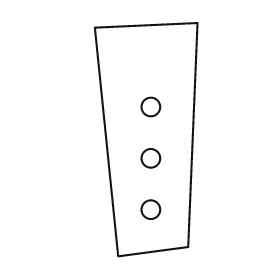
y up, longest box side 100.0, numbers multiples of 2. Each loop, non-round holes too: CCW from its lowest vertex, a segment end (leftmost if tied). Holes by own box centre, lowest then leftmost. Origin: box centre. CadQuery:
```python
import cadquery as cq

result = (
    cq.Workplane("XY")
    .moveTo(-12.0, -50.0)
    .lineTo(18.0, -46.0)
    .lineTo(22.0, 50.0)
    .lineTo(-22.0, 48.0)
    .close()
    .moveTo(2.0, -30.0)
    .circle(4.0)
    .moveTo(2.0, -8.0)
    .circle(4.0)
    .moveTo(2.0, 14.0)
    .circle(4.0)
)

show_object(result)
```